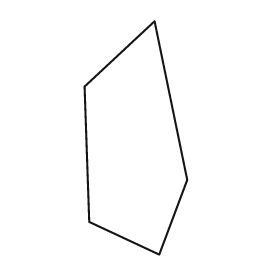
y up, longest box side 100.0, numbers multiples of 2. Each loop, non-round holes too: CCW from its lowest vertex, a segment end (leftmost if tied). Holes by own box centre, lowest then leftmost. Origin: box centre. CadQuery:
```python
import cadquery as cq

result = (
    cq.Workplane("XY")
    .moveTo(10.0, -50.0)
    .lineTo(22.0, -18.0)
    .lineTo(8.0, 50.0)
    .lineTo(-22.0, 22.0)
    .lineTo(-20.0, -36.0)
    .close()
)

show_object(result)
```